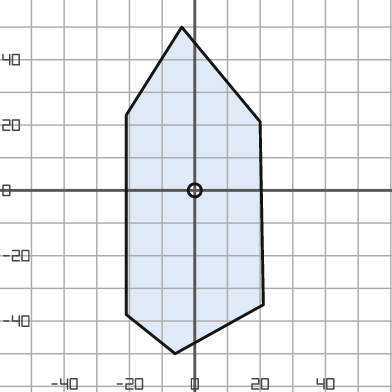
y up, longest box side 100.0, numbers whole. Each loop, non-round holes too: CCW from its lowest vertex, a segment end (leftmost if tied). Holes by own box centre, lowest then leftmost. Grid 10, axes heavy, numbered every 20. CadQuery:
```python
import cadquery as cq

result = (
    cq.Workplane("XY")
    .moveTo(-6.0, -50.0)
    .lineTo(21.0, -35.0)
    .lineTo(20.0, 21.0)
    .lineTo(-4.0, 50.0)
    .lineTo(-21.0, 23.0)
    .lineTo(-21.0, -38.0)
    .close()
    .moveTo(0.0, 0.0)
    .circle(2.0)
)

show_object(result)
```